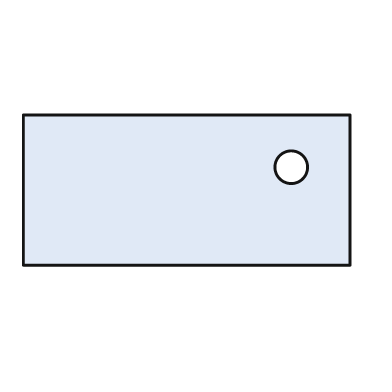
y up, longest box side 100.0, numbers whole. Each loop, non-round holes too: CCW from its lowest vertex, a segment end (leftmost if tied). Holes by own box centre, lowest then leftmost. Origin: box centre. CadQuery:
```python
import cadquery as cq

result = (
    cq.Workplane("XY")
    .moveTo(-50.0, -23.0)
    .lineTo(50.0, -23.0)
    .lineTo(50.0, 23.0)
    .lineTo(-50.0, 23.0)
    .close()
    .moveTo(32.0, 7.0)
    .circle(5.0)
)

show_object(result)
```